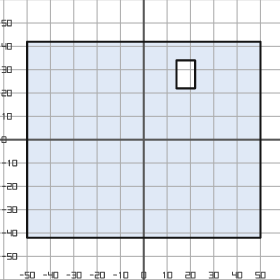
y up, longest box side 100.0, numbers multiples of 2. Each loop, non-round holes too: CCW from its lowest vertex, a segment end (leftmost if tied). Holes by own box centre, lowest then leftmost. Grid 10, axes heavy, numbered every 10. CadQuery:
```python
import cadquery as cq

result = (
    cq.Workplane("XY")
    .moveTo(-50.0, -42.0)
    .lineTo(50.0, -42.0)
    .lineTo(50.0, 42.0)
    .lineTo(-50.0, 42.0)
    .close()
    .moveTo(14.0, 22.0)
    .lineTo(22.0, 22.0)
    .lineTo(22.0, 34.0)
    .lineTo(14.0, 34.0)
    .close()
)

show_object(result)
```